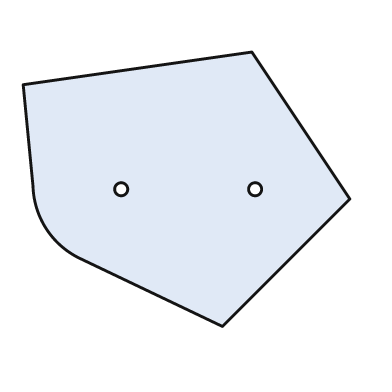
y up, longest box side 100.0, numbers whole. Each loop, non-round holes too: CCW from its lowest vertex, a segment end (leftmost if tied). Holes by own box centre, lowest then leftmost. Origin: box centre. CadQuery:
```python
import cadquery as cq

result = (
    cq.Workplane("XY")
    .moveTo(11.0, -42.0)
    .lineTo(50.0, -3.0)
    .lineTo(20.0, 42.0)
    .lineTo(-50.0, 32.0)
    .lineTo(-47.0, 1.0)
    .threePointArc((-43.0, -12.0), (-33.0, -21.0))
    .close()
    .moveTo(-20.0, 0.0)
    .circle(2.0)
    .moveTo(21.0, 0.0)
    .circle(2.0)
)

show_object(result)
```